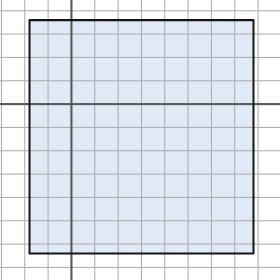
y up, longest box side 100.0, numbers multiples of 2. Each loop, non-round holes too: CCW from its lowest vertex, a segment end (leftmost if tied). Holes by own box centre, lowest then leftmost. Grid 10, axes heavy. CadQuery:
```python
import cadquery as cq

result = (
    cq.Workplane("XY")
    .moveTo(-18.0, -64.0)
    .lineTo(78.0, -64.0)
    .lineTo(78.0, 36.0)
    .lineTo(-18.0, 36.0)
    .close()
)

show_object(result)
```